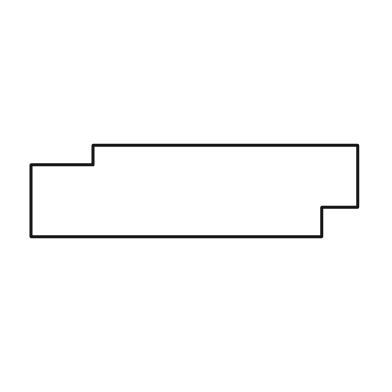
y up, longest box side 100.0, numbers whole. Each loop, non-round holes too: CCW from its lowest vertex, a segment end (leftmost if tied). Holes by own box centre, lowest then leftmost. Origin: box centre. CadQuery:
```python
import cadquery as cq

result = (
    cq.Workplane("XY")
    .moveTo(-50.0, -14.0)
    .lineTo(39.0, -14.0)
    .lineTo(39.0, -5.0)
    .lineTo(50.0, -5.0)
    .lineTo(50.0, 14.0)
    .lineTo(-31.0, 14.0)
    .lineTo(-31.0, 8.0)
    .lineTo(-50.0, 8.0)
    .close()
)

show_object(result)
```